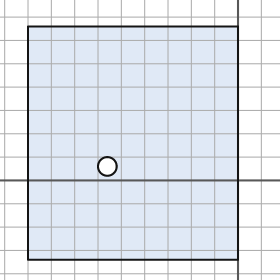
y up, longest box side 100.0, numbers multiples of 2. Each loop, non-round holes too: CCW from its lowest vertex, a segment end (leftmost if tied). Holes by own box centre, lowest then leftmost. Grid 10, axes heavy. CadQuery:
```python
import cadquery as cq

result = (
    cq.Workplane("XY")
    .moveTo(-90.0, -34.0)
    .lineTo(0.0, -34.0)
    .lineTo(0.0, 66.0)
    .lineTo(-90.0, 66.0)
    .close()
    .moveTo(-56.0, 6.0)
    .circle(4.0)
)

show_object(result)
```